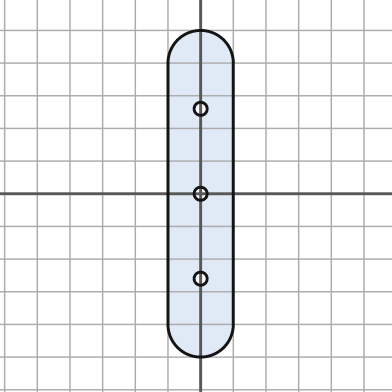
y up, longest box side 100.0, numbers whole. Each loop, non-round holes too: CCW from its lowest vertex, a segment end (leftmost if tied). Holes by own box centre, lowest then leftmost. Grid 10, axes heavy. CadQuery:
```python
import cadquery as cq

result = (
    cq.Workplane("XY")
    .moveTo(-10.0, -40.0)
    .threePointArc((0.0, -50.0), (10.0, -40.0))
    .lineTo(10.0, 40.0)
    .threePointArc((0.0, 50.0), (-10.0, 40.0))
    .close()
    .moveTo(0.0, -26.0)
    .circle(2.0)
    .moveTo(0.0, 0.0)
    .circle(2.0)
    .moveTo(0.0, 26.0)
    .circle(2.0)
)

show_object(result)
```